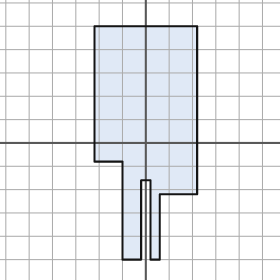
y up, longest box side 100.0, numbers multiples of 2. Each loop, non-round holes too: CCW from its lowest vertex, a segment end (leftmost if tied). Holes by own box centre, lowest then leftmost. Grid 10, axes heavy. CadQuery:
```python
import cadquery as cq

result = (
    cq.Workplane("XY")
    .moveTo(-10.0, -50.0)
    .lineTo(-2.0, -50.0)
    .lineTo(-2.0, -16.0)
    .lineTo(2.0, -16.0)
    .lineTo(2.0, -50.0)
    .lineTo(6.0, -50.0)
    .lineTo(6.0, -22.0)
    .lineTo(22.0, -22.0)
    .lineTo(22.0, 50.0)
    .lineTo(-22.0, 50.0)
    .lineTo(-22.0, -8.0)
    .lineTo(-10.0, -8.0)
    .close()
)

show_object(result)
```